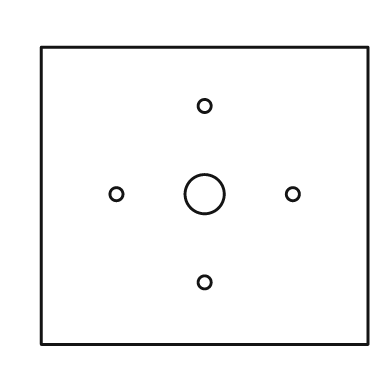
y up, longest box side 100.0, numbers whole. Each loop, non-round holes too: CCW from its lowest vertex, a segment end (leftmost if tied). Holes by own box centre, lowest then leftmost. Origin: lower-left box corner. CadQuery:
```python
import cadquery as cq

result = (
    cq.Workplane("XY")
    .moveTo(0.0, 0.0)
    .lineTo(100.0, 0.0)
    .lineTo(100.0, 91.0)
    .lineTo(0.0, 91.0)
    .close()
    .moveTo(50.0, 19.0)
    .circle(2.0)
    .moveTo(23.0, 46.0)
    .circle(2.0)
    .moveTo(50.0, 46.0)
    .circle(6.0)
    .moveTo(77.0, 46.0)
    .circle(2.0)
    .moveTo(50.0, 73.0)
    .circle(2.0)
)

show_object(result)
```